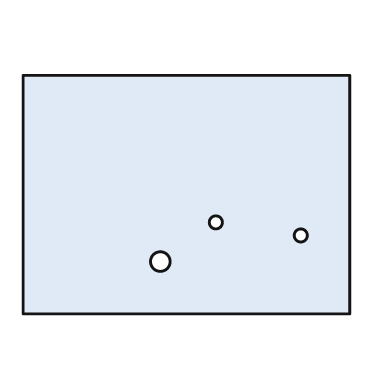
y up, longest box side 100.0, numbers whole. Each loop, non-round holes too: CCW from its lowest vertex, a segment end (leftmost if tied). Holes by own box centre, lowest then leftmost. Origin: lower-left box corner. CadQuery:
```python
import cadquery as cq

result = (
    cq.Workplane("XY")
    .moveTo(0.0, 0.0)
    .lineTo(100.0, 0.0)
    .lineTo(100.0, 73.0)
    .lineTo(0.0, 73.0)
    .close()
    .moveTo(42.0, 16.0)
    .circle(3.0)
    .moveTo(85.0, 24.0)
    .circle(2.0)
    .moveTo(59.0, 28.0)
    .circle(2.0)
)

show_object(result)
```